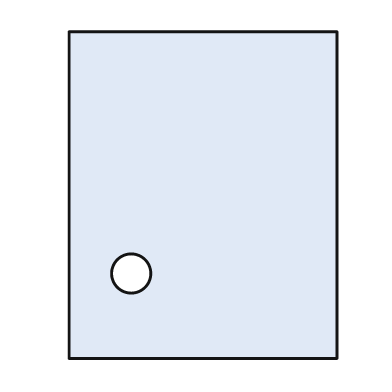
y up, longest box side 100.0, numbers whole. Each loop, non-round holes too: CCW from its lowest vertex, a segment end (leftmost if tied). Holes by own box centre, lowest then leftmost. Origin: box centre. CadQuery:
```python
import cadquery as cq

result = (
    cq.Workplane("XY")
    .moveTo(-41.0, -50.0)
    .lineTo(41.0, -50.0)
    .lineTo(41.0, 50.0)
    .lineTo(-41.0, 50.0)
    .close()
    .moveTo(-22.0, -24.0)
    .circle(6.0)
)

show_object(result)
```